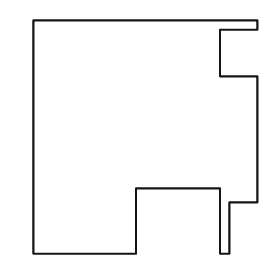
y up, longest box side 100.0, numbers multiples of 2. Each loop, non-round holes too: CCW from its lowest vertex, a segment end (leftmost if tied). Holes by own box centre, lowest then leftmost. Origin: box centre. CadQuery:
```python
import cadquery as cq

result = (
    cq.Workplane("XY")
    .moveTo(-48.0, -50.0)
    .lineTo(-4.0, -50.0)
    .lineTo(-4.0, -22.0)
    .lineTo(32.0, -22.0)
    .lineTo(32.0, -50.0)
    .lineTo(36.0, -50.0)
    .lineTo(36.0, -28.0)
    .lineTo(48.0, -28.0)
    .lineTo(48.0, 26.0)
    .lineTo(32.0, 26.0)
    .lineTo(32.0, 46.0)
    .lineTo(48.0, 46.0)
    .lineTo(48.0, 50.0)
    .lineTo(-48.0, 50.0)
    .close()
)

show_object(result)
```